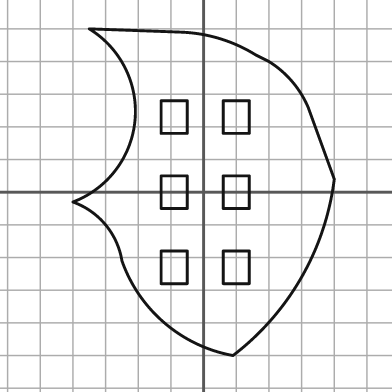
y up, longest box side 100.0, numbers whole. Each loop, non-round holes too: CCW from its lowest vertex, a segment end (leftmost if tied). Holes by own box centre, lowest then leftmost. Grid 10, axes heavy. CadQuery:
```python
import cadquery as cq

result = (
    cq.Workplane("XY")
    .moveTo(9.0, -50.0)
    .threePointArc((30.0, -26.0), (40.0, 4.0))
    .lineTo(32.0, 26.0)
    .threePointArc((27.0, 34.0), (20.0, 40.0))
    .lineTo(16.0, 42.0)
    .threePointArc((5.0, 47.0), (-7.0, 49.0))
    .lineTo(-35.0, 50.0)
    .threePointArc((-21.0, 22.0), (-40.0, -3.0))
    .threePointArc((-30.0, -10.0), (-25.0, -21.0))
    .threePointArc((-12.0, -40.0), (9.0, -50.0))
    .close()
    .moveTo(-13.0, -28.0)
    .lineTo(-5.0, -28.0)
    .lineTo(-5.0, -18.0)
    .lineTo(-13.0, -18.0)
    .close()
    .moveTo(6.0, -28.0)
    .lineTo(14.0, -28.0)
    .lineTo(14.0, -18.0)
    .lineTo(6.0, -18.0)
    .close()
    .moveTo(-13.0, -5.0)
    .lineTo(-5.0, -5.0)
    .lineTo(-5.0, 5.0)
    .lineTo(-13.0, 5.0)
    .close()
    .moveTo(6.0, -5.0)
    .lineTo(14.0, -5.0)
    .lineTo(14.0, 5.0)
    .lineTo(6.0, 5.0)
    .close()
    .moveTo(-13.0, 18.0)
    .lineTo(-5.0, 18.0)
    .lineTo(-5.0, 28.0)
    .lineTo(-13.0, 28.0)
    .close()
    .moveTo(6.0, 18.0)
    .lineTo(14.0, 18.0)
    .lineTo(14.0, 28.0)
    .lineTo(6.0, 28.0)
    .close()
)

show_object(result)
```